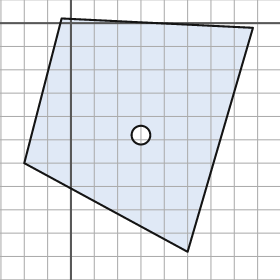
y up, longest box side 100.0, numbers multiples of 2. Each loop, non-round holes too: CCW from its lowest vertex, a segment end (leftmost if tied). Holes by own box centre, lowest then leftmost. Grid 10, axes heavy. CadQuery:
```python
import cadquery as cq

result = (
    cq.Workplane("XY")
    .moveTo(50.0, -98.0)
    .lineTo(78.0, -2.0)
    .lineTo(-4.0, 2.0)
    .lineTo(-20.0, -60.0)
    .close()
    .moveTo(30.0, -48.0)
    .circle(4.0)
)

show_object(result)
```